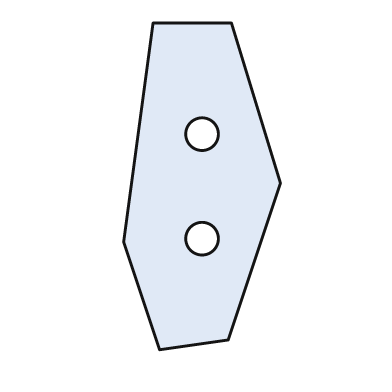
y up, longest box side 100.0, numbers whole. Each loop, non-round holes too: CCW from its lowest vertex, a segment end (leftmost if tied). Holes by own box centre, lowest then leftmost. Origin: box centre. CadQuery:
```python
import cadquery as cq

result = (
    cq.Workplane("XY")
    .moveTo(-13.0, -50.0)
    .lineTo(8.0, -47.0)
    .lineTo(24.0, 1.0)
    .lineTo(9.0, 50.0)
    .lineTo(-15.0, 50.0)
    .lineTo(-24.0, -17.0)
    .close()
    .moveTo(0.0, -16.0)
    .circle(5.0)
    .moveTo(0.0, 16.0)
    .circle(5.0)
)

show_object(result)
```